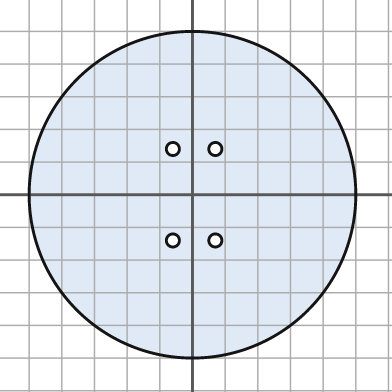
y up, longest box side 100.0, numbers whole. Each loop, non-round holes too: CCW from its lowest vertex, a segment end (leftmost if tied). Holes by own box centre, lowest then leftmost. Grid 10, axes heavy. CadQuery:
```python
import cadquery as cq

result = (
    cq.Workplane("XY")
    .moveTo(0.0, 0.0)
    .circle(50.0)
    .moveTo(-6.0, -14.0)
    .circle(2.0)
    .moveTo(7.0, -14.0)
    .circle(2.0)
    .moveTo(-6.0, 14.0)
    .circle(2.0)
    .moveTo(7.0, 14.0)
    .circle(2.0)
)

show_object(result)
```